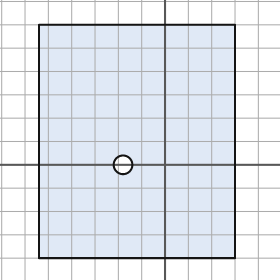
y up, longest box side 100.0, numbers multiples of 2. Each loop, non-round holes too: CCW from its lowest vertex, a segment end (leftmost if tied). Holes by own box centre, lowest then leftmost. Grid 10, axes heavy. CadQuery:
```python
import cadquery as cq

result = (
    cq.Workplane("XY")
    .moveTo(-54.0, -40.0)
    .lineTo(30.0, -40.0)
    .lineTo(30.0, 60.0)
    .lineTo(-54.0, 60.0)
    .close()
    .moveTo(-18.0, 0.0)
    .circle(4.0)
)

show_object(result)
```